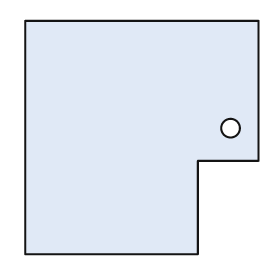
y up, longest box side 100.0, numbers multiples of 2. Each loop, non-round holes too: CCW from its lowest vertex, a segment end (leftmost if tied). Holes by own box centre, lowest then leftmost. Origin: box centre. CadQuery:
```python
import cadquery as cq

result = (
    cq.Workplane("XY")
    .moveTo(-50.0, -50.0)
    .lineTo(24.0, -50.0)
    .lineTo(24.0, -10.0)
    .lineTo(50.0, -10.0)
    .lineTo(50.0, 50.0)
    .lineTo(-50.0, 50.0)
    .close()
    .moveTo(38.0, 4.0)
    .circle(4.0)
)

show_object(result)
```